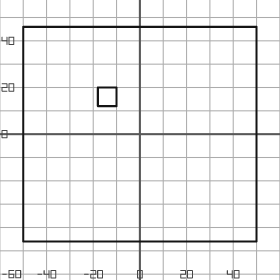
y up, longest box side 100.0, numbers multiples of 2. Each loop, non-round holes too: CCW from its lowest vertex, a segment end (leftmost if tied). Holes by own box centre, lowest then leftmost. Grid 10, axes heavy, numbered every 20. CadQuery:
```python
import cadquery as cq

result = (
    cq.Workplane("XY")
    .moveTo(-50.0, -46.0)
    .lineTo(50.0, -46.0)
    .lineTo(50.0, 46.0)
    .lineTo(-50.0, 46.0)
    .close()
    .moveTo(-18.0, 12.0)
    .lineTo(-10.0, 12.0)
    .lineTo(-10.0, 20.0)
    .lineTo(-18.0, 20.0)
    .close()
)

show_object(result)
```